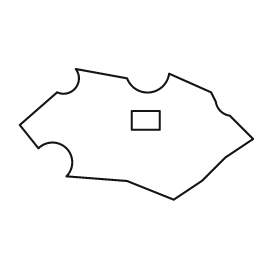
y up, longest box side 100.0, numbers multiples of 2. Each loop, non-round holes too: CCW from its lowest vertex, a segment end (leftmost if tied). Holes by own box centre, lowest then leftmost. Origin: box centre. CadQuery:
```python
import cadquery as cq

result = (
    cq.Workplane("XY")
    .moveTo(16.0, -28.0)
    .lineTo(28.0, -20.0)
    .lineTo(38.0, -10.0)
    .lineTo(50.0, -2.0)
    .lineTo(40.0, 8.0)
    .threePointArc((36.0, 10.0), (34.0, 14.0))
    .lineTo(32.0, 18.0)
    .lineTo(14.0, 26.0)
    .threePointArc((6.0, 18.0), (-4.0, 24.0))
    .lineTo(-26.0, 28.0)
    .threePointArc((-26.0, 20.0), (-34.0, 18.0))
    .lineTo(-50.0, 4.0)
    .lineTo(-42.0, -6.0)
    .threePointArc((-30.0, -6.0), (-30.0, -18.0))
    .lineTo(-4.0, -20.0)
    .close()
    .moveTo(-2.0, 2.0)
    .lineTo(10.0, 2.0)
    .lineTo(10.0, 10.0)
    .lineTo(-2.0, 10.0)
    .close()
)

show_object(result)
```